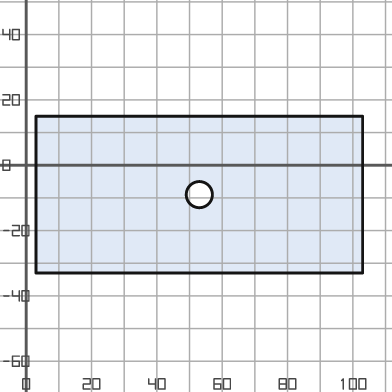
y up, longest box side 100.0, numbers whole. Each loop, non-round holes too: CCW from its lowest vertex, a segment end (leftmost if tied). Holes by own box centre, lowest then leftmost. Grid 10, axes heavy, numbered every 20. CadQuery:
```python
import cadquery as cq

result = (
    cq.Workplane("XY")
    .moveTo(3.0, -33.0)
    .lineTo(103.0, -33.0)
    .lineTo(103.0, 15.0)
    .lineTo(3.0, 15.0)
    .close()
    .moveTo(53.0, -9.0)
    .circle(4.0)
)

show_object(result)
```